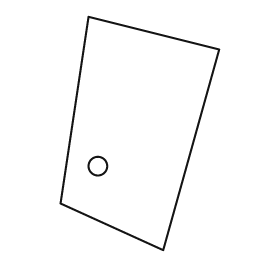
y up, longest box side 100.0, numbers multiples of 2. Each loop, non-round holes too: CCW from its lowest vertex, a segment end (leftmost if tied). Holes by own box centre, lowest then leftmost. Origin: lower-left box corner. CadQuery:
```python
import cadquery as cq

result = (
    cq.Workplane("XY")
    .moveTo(44.0, 0.0)
    .lineTo(68.0, 86.0)
    .lineTo(12.0, 100.0)
    .lineTo(0.0, 20.0)
    .close()
    .moveTo(16.0, 36.0)
    .circle(4.0)
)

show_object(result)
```